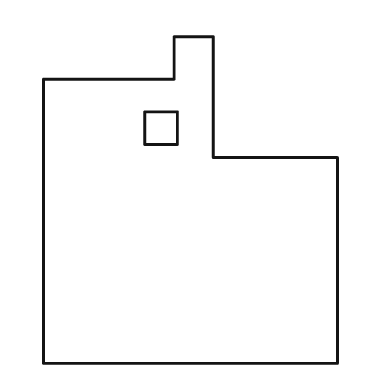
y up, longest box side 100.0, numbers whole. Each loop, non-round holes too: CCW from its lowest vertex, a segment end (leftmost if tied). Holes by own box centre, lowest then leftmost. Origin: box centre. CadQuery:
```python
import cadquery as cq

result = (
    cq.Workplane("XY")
    .moveTo(-45.0, -50.0)
    .lineTo(45.0, -50.0)
    .lineTo(45.0, 13.0)
    .lineTo(7.0, 13.0)
    .lineTo(7.0, 50.0)
    .lineTo(-5.0, 50.0)
    .lineTo(-5.0, 37.0)
    .lineTo(-45.0, 37.0)
    .close()
    .moveTo(-14.0, 17.0)
    .lineTo(-4.0, 17.0)
    .lineTo(-4.0, 27.0)
    .lineTo(-14.0, 27.0)
    .close()
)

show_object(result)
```